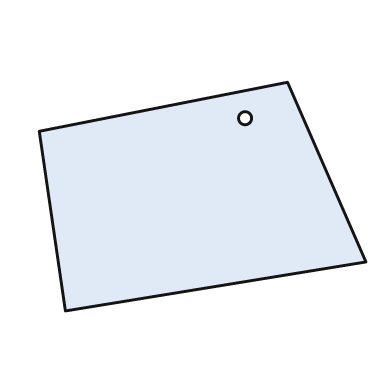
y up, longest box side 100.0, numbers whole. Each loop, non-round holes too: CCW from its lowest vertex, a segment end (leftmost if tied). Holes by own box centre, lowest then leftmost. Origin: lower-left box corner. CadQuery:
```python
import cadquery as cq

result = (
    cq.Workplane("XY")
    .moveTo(8.0, 0.0)
    .lineTo(100.0, 15.0)
    .lineTo(76.0, 70.0)
    .lineTo(0.0, 55.0)
    .close()
    .moveTo(63.0, 59.0)
    .circle(2.0)
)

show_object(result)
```